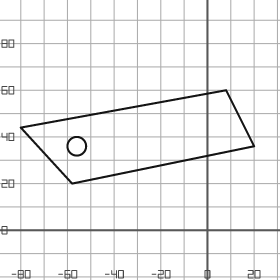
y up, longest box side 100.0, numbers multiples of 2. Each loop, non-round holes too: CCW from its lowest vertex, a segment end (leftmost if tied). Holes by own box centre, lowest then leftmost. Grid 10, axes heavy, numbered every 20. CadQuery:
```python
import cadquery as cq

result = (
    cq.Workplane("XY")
    .moveTo(-58.0, 20.0)
    .lineTo(20.0, 36.0)
    .lineTo(8.0, 60.0)
    .lineTo(-80.0, 44.0)
    .close()
    .moveTo(-56.0, 36.0)
    .circle(4.0)
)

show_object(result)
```